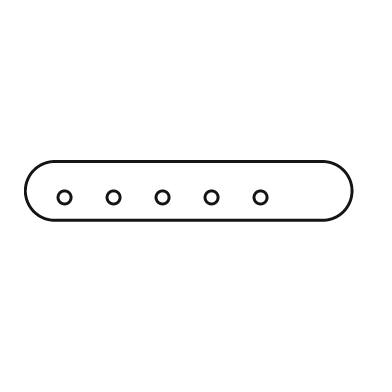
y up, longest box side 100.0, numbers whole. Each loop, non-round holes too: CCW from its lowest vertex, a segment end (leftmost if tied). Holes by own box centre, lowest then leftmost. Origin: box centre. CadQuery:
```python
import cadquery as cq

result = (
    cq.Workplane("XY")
    .moveTo(-41.0, -9.0)
    .lineTo(41.0, -9.0)
    .threePointArc((50.0, 0.0), (41.0, 9.0))
    .lineTo(-41.0, 9.0)
    .threePointArc((-50.0, 0.0), (-41.0, -9.0))
    .close()
    .moveTo(-38.0, -2.0)
    .circle(2.0)
    .moveTo(-23.0, -2.0)
    .circle(2.0)
    .moveTo(-8.0, -2.0)
    .circle(2.0)
    .moveTo(7.0, -2.0)
    .circle(2.0)
    .moveTo(22.0, -2.0)
    .circle(2.0)
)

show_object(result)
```